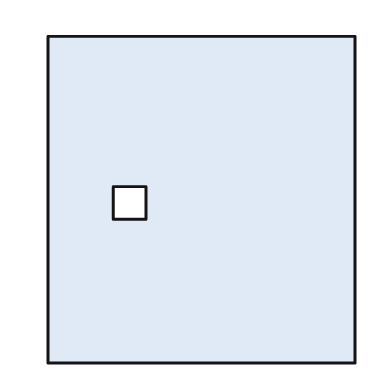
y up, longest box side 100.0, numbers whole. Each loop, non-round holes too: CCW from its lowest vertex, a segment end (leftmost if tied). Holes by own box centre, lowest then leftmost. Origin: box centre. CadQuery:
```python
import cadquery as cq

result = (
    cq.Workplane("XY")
    .moveTo(-47.0, -50.0)
    .lineTo(47.0, -50.0)
    .lineTo(47.0, 50.0)
    .lineTo(-47.0, 50.0)
    .close()
    .moveTo(-27.0, -6.0)
    .lineTo(-17.0, -6.0)
    .lineTo(-17.0, 4.0)
    .lineTo(-27.0, 4.0)
    .close()
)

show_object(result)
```